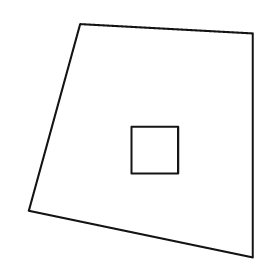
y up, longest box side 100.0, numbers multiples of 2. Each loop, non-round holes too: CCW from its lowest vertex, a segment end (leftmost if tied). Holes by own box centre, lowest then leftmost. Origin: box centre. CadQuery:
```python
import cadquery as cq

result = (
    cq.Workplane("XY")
    .moveTo(48.0, -50.0)
    .lineTo(48.0, 46.0)
    .lineTo(-26.0, 50.0)
    .lineTo(-48.0, -30.0)
    .close()
    .moveTo(-4.0, -14.0)
    .lineTo(16.0, -14.0)
    .lineTo(16.0, 6.0)
    .lineTo(-4.0, 6.0)
    .close()
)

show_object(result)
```